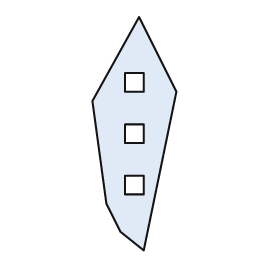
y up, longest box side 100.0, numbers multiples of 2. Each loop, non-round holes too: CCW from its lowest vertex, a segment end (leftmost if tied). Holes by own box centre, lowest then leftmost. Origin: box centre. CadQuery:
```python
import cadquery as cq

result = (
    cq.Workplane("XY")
    .moveTo(4.0, -50.0)
    .lineTo(18.0, 18.0)
    .lineTo(2.0, 50.0)
    .lineTo(-18.0, 14.0)
    .lineTo(-12.0, -30.0)
    .lineTo(-6.0, -42.0)
    .close()
    .moveTo(-4.0, -26.0)
    .lineTo(4.0, -26.0)
    .lineTo(4.0, -18.0)
    .lineTo(-4.0, -18.0)
    .close()
    .moveTo(-4.0, -4.0)
    .lineTo(4.0, -4.0)
    .lineTo(4.0, 4.0)
    .lineTo(-4.0, 4.0)
    .close()
    .moveTo(-4.0, 18.0)
    .lineTo(4.0, 18.0)
    .lineTo(4.0, 26.0)
    .lineTo(-4.0, 26.0)
    .close()
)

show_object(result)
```